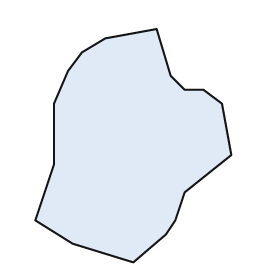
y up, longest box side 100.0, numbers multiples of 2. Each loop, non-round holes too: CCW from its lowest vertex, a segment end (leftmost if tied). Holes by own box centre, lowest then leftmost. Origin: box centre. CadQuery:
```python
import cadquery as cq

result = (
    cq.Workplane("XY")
    .moveTo(0.0, -50.0)
    .lineTo(14.0, -38.0)
    .lineTo(18.0, -32.0)
    .lineTo(22.0, -20.0)
    .lineTo(42.0, -4.0)
    .lineTo(38.0, 18.0)
    .lineTo(30.0, 24.0)
    .lineTo(22.0, 24.0)
    .lineTo(16.0, 30.0)
    .lineTo(10.0, 50.0)
    .lineTo(-12.0, 46.0)
    .lineTo(-22.0, 40.0)
    .lineTo(-28.0, 32.0)
    .lineTo(-34.0, 18.0)
    .lineTo(-34.0, -8.0)
    .lineTo(-42.0, -32.0)
    .lineTo(-26.0, -42.0)
    .close()
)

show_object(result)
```